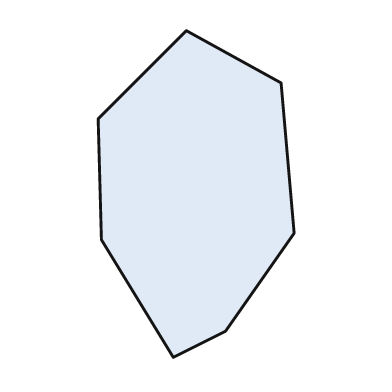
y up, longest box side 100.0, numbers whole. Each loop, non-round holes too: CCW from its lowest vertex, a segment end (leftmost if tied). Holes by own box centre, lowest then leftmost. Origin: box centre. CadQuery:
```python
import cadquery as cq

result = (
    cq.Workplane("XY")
    .moveTo(-7.0, -50.0)
    .lineTo(9.0, -42.0)
    .lineTo(30.0, -12.0)
    .lineTo(26.0, 34.0)
    .lineTo(-3.0, 50.0)
    .lineTo(-30.0, 23.0)
    .lineTo(-29.0, -14.0)
    .close()
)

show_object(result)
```